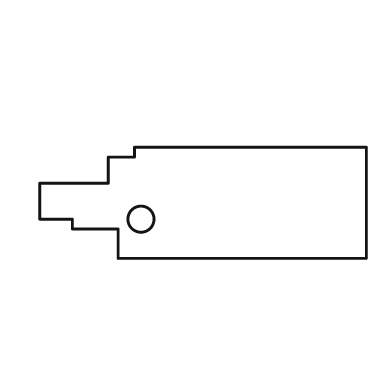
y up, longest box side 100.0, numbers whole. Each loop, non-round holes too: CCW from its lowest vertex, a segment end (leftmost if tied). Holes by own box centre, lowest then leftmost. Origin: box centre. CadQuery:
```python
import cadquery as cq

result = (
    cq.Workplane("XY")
    .moveTo(-26.0, -17.0)
    .lineTo(50.0, -17.0)
    .lineTo(50.0, 17.0)
    .lineTo(-21.0, 17.0)
    .lineTo(-21.0, 14.0)
    .lineTo(-29.0, 14.0)
    .lineTo(-29.0, 6.0)
    .lineTo(-50.0, 6.0)
    .lineTo(-50.0, -5.0)
    .lineTo(-40.0, -5.0)
    .lineTo(-40.0, -8.0)
    .lineTo(-26.0, -8.0)
    .close()
    .moveTo(-19.0, -5.0)
    .circle(4.0)
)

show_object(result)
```